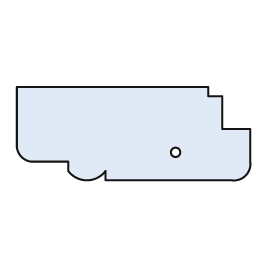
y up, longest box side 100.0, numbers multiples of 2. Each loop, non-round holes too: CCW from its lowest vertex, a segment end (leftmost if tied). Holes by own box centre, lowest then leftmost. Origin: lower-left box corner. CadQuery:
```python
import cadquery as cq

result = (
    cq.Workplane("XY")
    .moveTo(38.0, 0.0)
    .lineTo(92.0, 0.0)
    .threePointArc((98.0, 2.0), (100.0, 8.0))
    .lineTo(100.0, 22.0)
    .lineTo(88.0, 22.0)
    .lineTo(88.0, 36.0)
    .lineTo(82.0, 36.0)
    .lineTo(82.0, 40.0)
    .lineTo(0.0, 40.0)
    .lineTo(0.0, 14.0)
    .threePointArc((2.0, 10.0), (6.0, 8.0))
    .lineTo(22.0, 8.0)
    .lineTo(22.0, 4.0)
    .threePointArc((30.0, 0.0), (38.0, 4.0))
    .close()
    .moveTo(68.0, 12.0)
    .circle(2.0)
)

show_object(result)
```